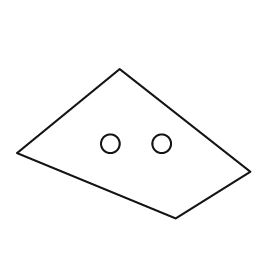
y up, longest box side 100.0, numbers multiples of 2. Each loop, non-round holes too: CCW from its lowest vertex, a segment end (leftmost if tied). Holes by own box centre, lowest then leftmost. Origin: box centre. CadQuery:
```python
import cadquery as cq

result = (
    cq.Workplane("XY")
    .moveTo(18.0, -32.0)
    .lineTo(50.0, -12.0)
    .lineTo(-6.0, 32.0)
    .lineTo(-50.0, -4.0)
    .close()
    .moveTo(-10.0, 0.0)
    .circle(4.0)
    .moveTo(12.0, 0.0)
    .circle(4.0)
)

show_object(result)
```